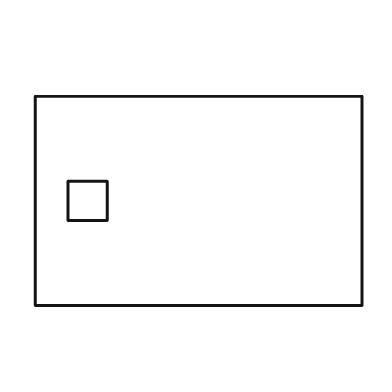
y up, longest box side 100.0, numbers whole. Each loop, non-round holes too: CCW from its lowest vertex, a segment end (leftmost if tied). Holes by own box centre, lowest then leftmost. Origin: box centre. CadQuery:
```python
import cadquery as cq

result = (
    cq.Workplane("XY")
    .moveTo(-50.0, -32.0)
    .lineTo(50.0, -32.0)
    .lineTo(50.0, 32.0)
    .lineTo(-50.0, 32.0)
    .close()
    .moveTo(-40.0, -6.0)
    .lineTo(-28.0, -6.0)
    .lineTo(-28.0, 6.0)
    .lineTo(-40.0, 6.0)
    .close()
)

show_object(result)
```